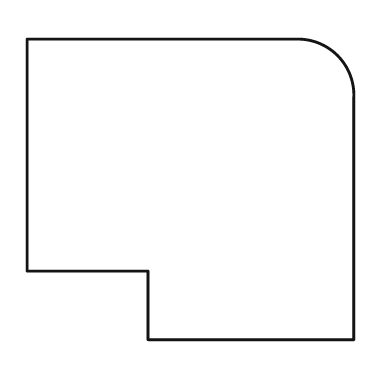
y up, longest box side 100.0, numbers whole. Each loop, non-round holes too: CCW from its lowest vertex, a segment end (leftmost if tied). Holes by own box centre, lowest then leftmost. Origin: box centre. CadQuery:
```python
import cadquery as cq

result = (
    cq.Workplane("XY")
    .moveTo(-13.0, -46.0)
    .lineTo(50.0, -46.0)
    .lineTo(50.0, 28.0)
    .threePointArc((45.0, 41.0), (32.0, 46.0))
    .lineTo(-50.0, 46.0)
    .lineTo(-50.0, -25.0)
    .lineTo(-13.0, -25.0)
    .close()
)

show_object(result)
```